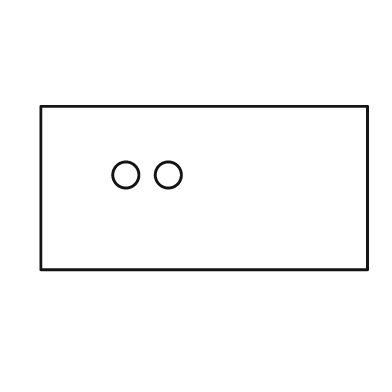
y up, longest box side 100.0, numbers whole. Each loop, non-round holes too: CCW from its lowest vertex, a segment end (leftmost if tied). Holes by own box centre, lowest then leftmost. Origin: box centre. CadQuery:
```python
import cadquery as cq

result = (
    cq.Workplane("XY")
    .moveTo(-50.0, -25.0)
    .lineTo(50.0, -25.0)
    .lineTo(50.0, 25.0)
    .lineTo(-50.0, 25.0)
    .close()
    .moveTo(-24.0, 4.0)
    .circle(4.0)
    .moveTo(-11.0, 4.0)
    .circle(4.0)
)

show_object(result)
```